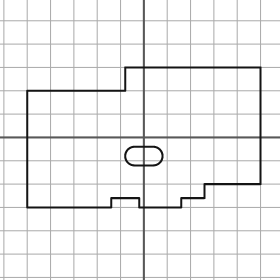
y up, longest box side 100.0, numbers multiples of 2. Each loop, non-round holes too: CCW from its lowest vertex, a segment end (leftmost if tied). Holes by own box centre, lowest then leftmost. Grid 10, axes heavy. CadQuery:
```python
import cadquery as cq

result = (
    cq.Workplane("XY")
    .moveTo(-50.0, -30.0)
    .lineTo(-14.0, -30.0)
    .lineTo(-14.0, -26.0)
    .lineTo(-2.0, -26.0)
    .lineTo(-2.0, -30.0)
    .lineTo(16.0, -30.0)
    .lineTo(16.0, -26.0)
    .lineTo(26.0, -26.0)
    .lineTo(26.0, -20.0)
    .lineTo(50.0, -20.0)
    .lineTo(50.0, 30.0)
    .lineTo(-8.0, 30.0)
    .lineTo(-8.0, 20.0)
    .lineTo(-50.0, 20.0)
    .close()
    .moveTo(-4.0, -12.0)
    .lineTo(4.0, -12.0)
    .threePointArc((8.0, -8.0), (4.0, -4.0))
    .lineTo(-4.0, -4.0)
    .threePointArc((-8.0, -8.0), (-4.0, -12.0))
    .close()
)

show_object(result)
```